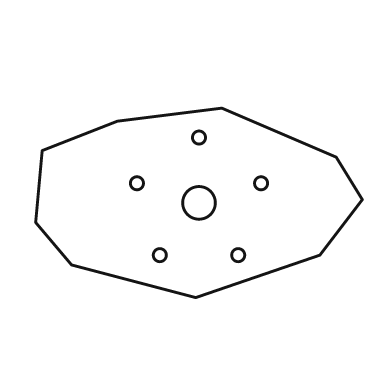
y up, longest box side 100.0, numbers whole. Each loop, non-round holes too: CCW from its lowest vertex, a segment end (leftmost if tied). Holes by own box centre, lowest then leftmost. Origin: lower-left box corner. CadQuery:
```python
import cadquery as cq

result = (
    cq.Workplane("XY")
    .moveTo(49.0, 0.0)
    .lineTo(87.0, 13.0)
    .lineTo(100.0, 30.0)
    .lineTo(92.0, 43.0)
    .lineTo(57.0, 58.0)
    .lineTo(25.0, 54.0)
    .lineTo(2.0, 45.0)
    .lineTo(0.0, 23.0)
    .lineTo(11.0, 10.0)
    .close()
    .moveTo(38.0, 13.0)
    .circle(2.0)
    .moveTo(62.0, 13.0)
    .circle(2.0)
    .moveTo(50.0, 29.0)
    .circle(5.0)
    .moveTo(31.0, 35.0)
    .circle(2.0)
    .moveTo(69.0, 35.0)
    .circle(2.0)
    .moveTo(50.0, 49.0)
    .circle(2.0)
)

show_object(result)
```